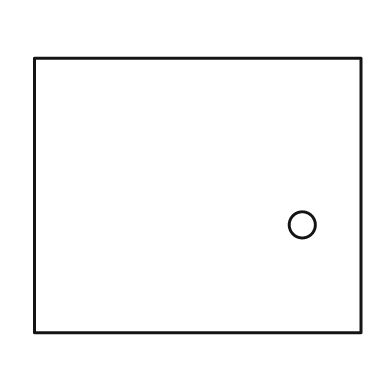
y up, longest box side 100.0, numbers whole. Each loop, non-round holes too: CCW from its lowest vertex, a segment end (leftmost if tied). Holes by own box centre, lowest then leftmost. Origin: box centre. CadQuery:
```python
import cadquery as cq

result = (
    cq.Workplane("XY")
    .moveTo(-50.0, -42.0)
    .lineTo(50.0, -42.0)
    .lineTo(50.0, 42.0)
    .lineTo(-50.0, 42.0)
    .close()
    .moveTo(32.0, -9.0)
    .circle(4.0)
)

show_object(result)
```